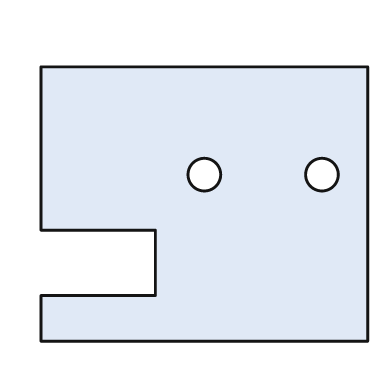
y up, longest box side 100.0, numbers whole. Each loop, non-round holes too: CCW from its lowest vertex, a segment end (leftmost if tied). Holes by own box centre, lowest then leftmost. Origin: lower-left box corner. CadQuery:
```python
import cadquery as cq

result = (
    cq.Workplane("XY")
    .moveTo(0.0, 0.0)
    .lineTo(100.0, 0.0)
    .lineTo(100.0, 84.0)
    .lineTo(0.0, 84.0)
    .lineTo(0.0, 34.0)
    .lineTo(35.0, 34.0)
    .lineTo(35.0, 14.0)
    .lineTo(0.0, 14.0)
    .close()
    .moveTo(50.0, 51.0)
    .circle(5.0)
    .moveTo(86.0, 51.0)
    .circle(5.0)
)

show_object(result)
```